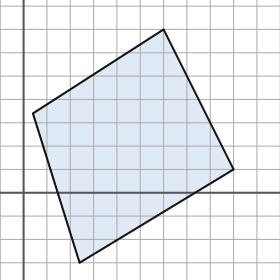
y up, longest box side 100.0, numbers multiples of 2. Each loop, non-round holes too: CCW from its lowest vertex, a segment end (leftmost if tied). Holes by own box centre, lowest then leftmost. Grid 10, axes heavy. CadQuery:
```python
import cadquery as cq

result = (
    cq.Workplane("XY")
    .moveTo(24.0, -30.0)
    .lineTo(90.0, 10.0)
    .lineTo(60.0, 70.0)
    .lineTo(4.0, 34.0)
    .close()
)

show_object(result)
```